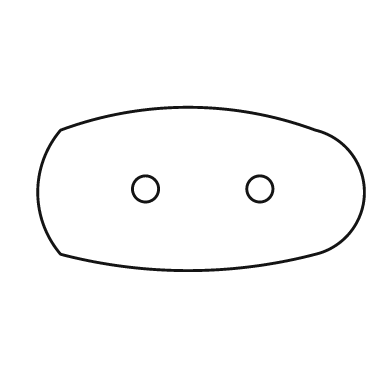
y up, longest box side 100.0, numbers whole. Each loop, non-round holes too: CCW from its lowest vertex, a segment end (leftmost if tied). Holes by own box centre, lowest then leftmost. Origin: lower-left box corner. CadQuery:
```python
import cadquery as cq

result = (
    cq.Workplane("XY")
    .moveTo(7.0, 5.0)
    .threePointArc((46.0, 0.0), (85.0, 5.0))
    .threePointArc((100.0, 24.0), (85.0, 43.0))
    .threePointArc((46.0, 50.0), (7.0, 43.0))
    .threePointArc((0.0, 24.0), (7.0, 5.0))
    .close()
    .moveTo(33.0, 25.0)
    .circle(4.0)
    .moveTo(68.0, 25.0)
    .circle(4.0)
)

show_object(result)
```